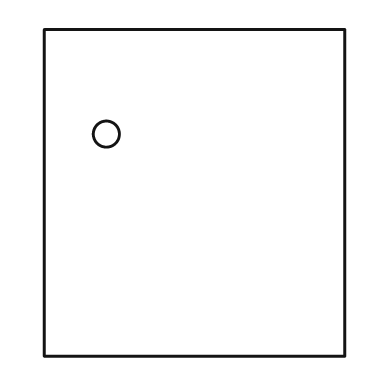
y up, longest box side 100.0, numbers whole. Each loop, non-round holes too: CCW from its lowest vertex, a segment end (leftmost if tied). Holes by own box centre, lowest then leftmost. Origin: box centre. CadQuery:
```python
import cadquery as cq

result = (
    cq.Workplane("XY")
    .moveTo(-46.0, -50.0)
    .lineTo(46.0, -50.0)
    .lineTo(46.0, 50.0)
    .lineTo(-46.0, 50.0)
    .close()
    .moveTo(-27.0, 18.0)
    .circle(4.0)
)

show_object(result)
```